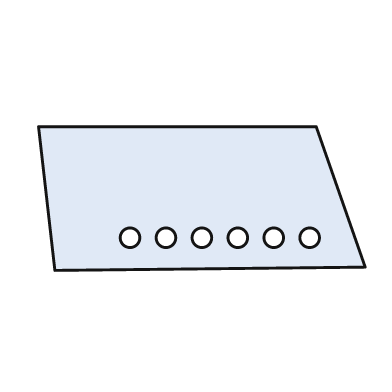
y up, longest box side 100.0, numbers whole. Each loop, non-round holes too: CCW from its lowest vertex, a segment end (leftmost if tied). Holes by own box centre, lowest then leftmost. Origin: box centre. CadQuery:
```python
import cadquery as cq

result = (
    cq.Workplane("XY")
    .moveTo(-45.0, -22.0)
    .lineTo(50.0, -21.0)
    .lineTo(35.0, 22.0)
    .lineTo(-50.0, 22.0)
    .close()
    .moveTo(-22.0, -12.0)
    .circle(3.0)
    .moveTo(-11.0, -12.0)
    .circle(3.0)
    .moveTo(0.0, -12.0)
    .circle(3.0)
    .moveTo(11.0, -12.0)
    .circle(3.0)
    .moveTo(22.0, -12.0)
    .circle(3.0)
    .moveTo(33.0, -12.0)
    .circle(3.0)
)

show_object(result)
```